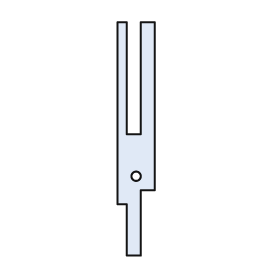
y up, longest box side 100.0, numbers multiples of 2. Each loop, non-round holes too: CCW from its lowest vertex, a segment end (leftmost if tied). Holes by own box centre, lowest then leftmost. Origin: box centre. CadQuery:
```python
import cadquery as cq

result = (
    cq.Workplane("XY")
    .moveTo(-4.0, -50.0)
    .lineTo(2.0, -50.0)
    .lineTo(2.0, -22.0)
    .lineTo(8.0, -22.0)
    .lineTo(8.0, 50.0)
    .lineTo(2.0, 50.0)
    .lineTo(2.0, 2.0)
    .lineTo(-4.0, 2.0)
    .lineTo(-4.0, 50.0)
    .lineTo(-8.0, 50.0)
    .lineTo(-8.0, -28.0)
    .lineTo(-4.0, -28.0)
    .close()
    .moveTo(0.0, -16.0)
    .circle(2.0)
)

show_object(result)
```